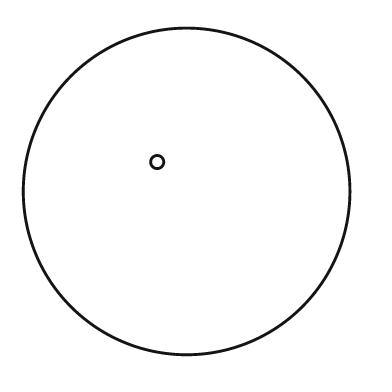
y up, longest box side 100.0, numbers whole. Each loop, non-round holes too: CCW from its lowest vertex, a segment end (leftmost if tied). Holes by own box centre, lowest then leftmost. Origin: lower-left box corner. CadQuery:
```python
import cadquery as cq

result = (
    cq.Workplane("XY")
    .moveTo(50.0, 50.0)
    .circle(50.0)
    .moveTo(41.0, 59.0)
    .circle(2.0)
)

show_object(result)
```